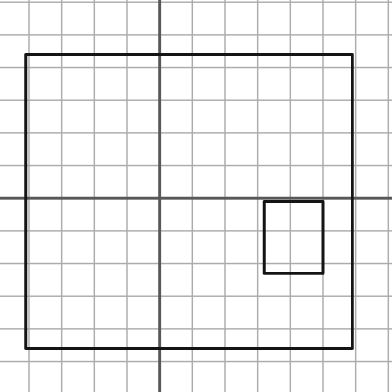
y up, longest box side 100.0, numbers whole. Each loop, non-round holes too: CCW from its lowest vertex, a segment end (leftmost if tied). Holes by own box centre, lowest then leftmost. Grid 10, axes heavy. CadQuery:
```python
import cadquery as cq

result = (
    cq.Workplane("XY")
    .moveTo(-41.0, -46.0)
    .lineTo(59.0, -46.0)
    .lineTo(59.0, 44.0)
    .lineTo(-41.0, 44.0)
    .close()
    .moveTo(32.0, -23.0)
    .lineTo(50.0, -23.0)
    .lineTo(50.0, -1.0)
    .lineTo(32.0, -1.0)
    .close()
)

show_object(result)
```